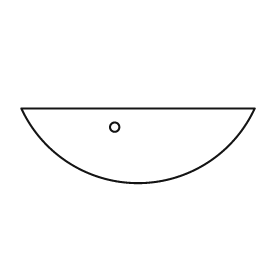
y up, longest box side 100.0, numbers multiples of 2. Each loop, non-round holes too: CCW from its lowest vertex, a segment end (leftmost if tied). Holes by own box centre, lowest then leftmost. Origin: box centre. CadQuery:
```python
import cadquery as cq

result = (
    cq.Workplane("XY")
    .moveTo(-50.0, 16.0)
    .threePointArc((0.0, -16.0), (50.0, 16.0))
    .close()
    .moveTo(-10.0, 8.0)
    .circle(2.0)
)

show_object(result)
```